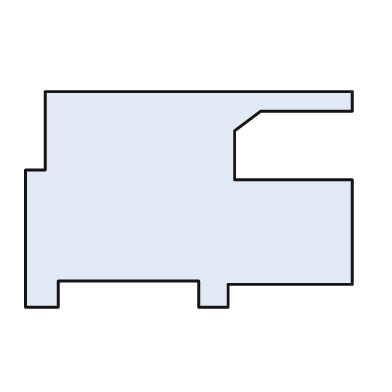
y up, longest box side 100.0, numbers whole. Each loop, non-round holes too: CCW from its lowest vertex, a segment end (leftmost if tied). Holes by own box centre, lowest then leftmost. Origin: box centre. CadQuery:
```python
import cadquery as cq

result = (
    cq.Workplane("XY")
    .moveTo(-50.0, -33.0)
    .lineTo(-40.0, -33.0)
    .lineTo(-40.0, -25.0)
    .lineTo(3.0, -25.0)
    .lineTo(3.0, -33.0)
    .lineTo(12.0, -33.0)
    .lineTo(12.0, -26.0)
    .lineTo(50.0, -26.0)
    .lineTo(50.0, 6.0)
    .lineTo(14.0, 6.0)
    .lineTo(14.0, 21.0)
    .lineTo(22.0, 27.0)
    .lineTo(50.0, 27.0)
    .lineTo(50.0, 33.0)
    .lineTo(-44.0, 33.0)
    .lineTo(-44.0, 9.0)
    .lineTo(-50.0, 9.0)
    .close()
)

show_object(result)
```